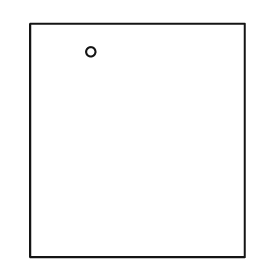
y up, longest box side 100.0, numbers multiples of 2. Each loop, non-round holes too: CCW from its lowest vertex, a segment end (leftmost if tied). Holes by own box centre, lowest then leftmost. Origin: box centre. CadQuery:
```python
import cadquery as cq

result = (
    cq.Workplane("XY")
    .moveTo(-46.0, -50.0)
    .lineTo(46.0, -50.0)
    .lineTo(46.0, 50.0)
    .lineTo(-46.0, 50.0)
    .close()
    .moveTo(-20.0, 38.0)
    .circle(2.0)
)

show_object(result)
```